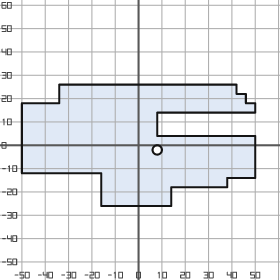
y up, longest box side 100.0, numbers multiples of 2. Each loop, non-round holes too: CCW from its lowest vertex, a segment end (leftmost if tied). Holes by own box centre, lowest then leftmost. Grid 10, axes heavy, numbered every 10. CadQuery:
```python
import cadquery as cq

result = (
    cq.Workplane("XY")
    .moveTo(-16.0, -26.0)
    .lineTo(14.0, -26.0)
    .lineTo(14.0, -18.0)
    .lineTo(38.0, -18.0)
    .lineTo(38.0, -14.0)
    .lineTo(50.0, -14.0)
    .lineTo(50.0, 4.0)
    .lineTo(8.0, 4.0)
    .lineTo(8.0, 14.0)
    .lineTo(50.0, 14.0)
    .lineTo(50.0, 18.0)
    .lineTo(46.0, 18.0)
    .lineTo(46.0, 22.0)
    .lineTo(42.0, 22.0)
    .lineTo(42.0, 26.0)
    .lineTo(-34.0, 26.0)
    .lineTo(-34.0, 18.0)
    .lineTo(-50.0, 18.0)
    .lineTo(-50.0, -12.0)
    .lineTo(-16.0, -12.0)
    .close()
    .moveTo(8.0, -2.0)
    .circle(2.0)
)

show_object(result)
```